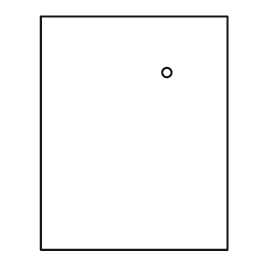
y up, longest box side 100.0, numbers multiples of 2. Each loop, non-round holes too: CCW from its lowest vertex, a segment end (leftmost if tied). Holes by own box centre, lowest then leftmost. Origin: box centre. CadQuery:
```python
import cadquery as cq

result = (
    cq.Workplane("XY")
    .moveTo(-40.0, -50.0)
    .lineTo(40.0, -50.0)
    .lineTo(40.0, 50.0)
    .lineTo(-40.0, 50.0)
    .close()
    .moveTo(14.0, 26.0)
    .circle(2.0)
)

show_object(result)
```